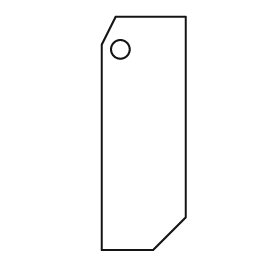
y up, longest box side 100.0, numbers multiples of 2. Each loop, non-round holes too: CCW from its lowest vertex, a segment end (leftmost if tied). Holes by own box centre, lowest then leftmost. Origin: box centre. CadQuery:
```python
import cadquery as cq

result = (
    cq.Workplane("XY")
    .moveTo(-18.0, -50.0)
    .lineTo(4.0, -50.0)
    .lineTo(18.0, -36.0)
    .lineTo(18.0, 50.0)
    .lineTo(-12.0, 50.0)
    .lineTo(-18.0, 38.0)
    .close()
    .moveTo(-10.0, 36.0)
    .circle(4.0)
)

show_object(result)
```